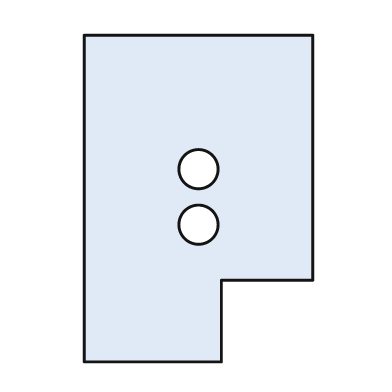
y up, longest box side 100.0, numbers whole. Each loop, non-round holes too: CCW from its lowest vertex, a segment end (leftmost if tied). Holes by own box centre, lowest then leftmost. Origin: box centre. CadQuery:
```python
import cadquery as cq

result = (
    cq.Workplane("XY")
    .moveTo(-35.0, -50.0)
    .lineTo(7.0, -50.0)
    .lineTo(7.0, -25.0)
    .lineTo(35.0, -25.0)
    .lineTo(35.0, 50.0)
    .lineTo(-35.0, 50.0)
    .close()
    .moveTo(0.0, -8.0)
    .circle(6.0)
    .moveTo(0.0, 9.0)
    .circle(6.0)
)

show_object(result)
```